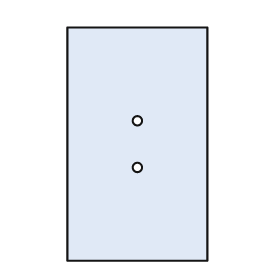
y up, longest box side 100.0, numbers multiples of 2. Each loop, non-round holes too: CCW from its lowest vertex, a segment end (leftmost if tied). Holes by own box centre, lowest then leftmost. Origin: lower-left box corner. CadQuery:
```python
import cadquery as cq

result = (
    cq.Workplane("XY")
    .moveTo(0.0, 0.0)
    .lineTo(60.0, 0.0)
    .lineTo(60.0, 100.0)
    .lineTo(0.0, 100.0)
    .close()
    .moveTo(30.0, 40.0)
    .circle(2.0)
    .moveTo(30.0, 60.0)
    .circle(2.0)
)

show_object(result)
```